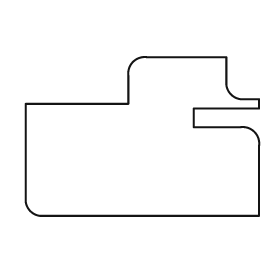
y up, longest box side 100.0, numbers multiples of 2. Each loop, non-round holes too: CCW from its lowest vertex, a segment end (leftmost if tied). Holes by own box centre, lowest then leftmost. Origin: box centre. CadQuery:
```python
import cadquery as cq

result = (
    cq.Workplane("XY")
    .moveTo(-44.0, -34.0)
    .lineTo(50.0, -34.0)
    .lineTo(50.0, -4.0)
    .threePointArc((48.0, 2.0), (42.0, 4.0))
    .lineTo(22.0, 4.0)
    .lineTo(22.0, 12.0)
    .lineTo(50.0, 12.0)
    .lineTo(50.0, 16.0)
    .lineTo(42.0, 16.0)
    .threePointArc((38.0, 18.0), (36.0, 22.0))
    .lineTo(36.0, 34.0)
    .lineTo(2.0, 34.0)
    .threePointArc((-4.0, 32.0), (-6.0, 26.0))
    .lineTo(-6.0, 14.0)
    .lineTo(-50.0, 14.0)
    .lineTo(-50.0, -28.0)
    .threePointArc((-48.0, -32.0), (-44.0, -34.0))
    .close()
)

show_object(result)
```